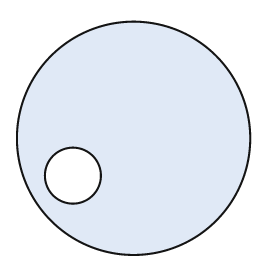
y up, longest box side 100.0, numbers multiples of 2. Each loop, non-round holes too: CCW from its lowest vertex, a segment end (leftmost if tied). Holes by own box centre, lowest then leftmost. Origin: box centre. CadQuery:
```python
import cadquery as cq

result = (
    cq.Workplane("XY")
    .moveTo(0.0, 0.0)
    .circle(50.0)
    .moveTo(-26.0, -16.0)
    .circle(12.0)
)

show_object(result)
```